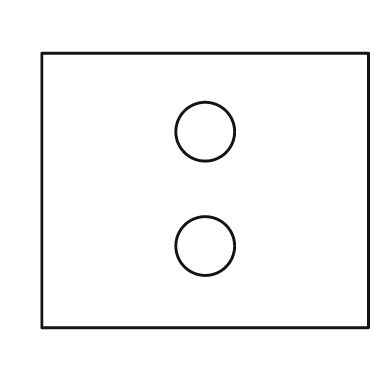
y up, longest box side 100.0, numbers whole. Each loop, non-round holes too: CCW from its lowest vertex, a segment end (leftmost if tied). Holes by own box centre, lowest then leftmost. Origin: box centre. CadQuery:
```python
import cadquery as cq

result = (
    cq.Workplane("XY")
    .moveTo(-50.0, -42.0)
    .lineTo(50.0, -42.0)
    .lineTo(50.0, 42.0)
    .lineTo(-50.0, 42.0)
    .close()
    .moveTo(0.0, -17.0)
    .circle(9.0)
    .moveTo(0.0, 18.0)
    .circle(9.0)
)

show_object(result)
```